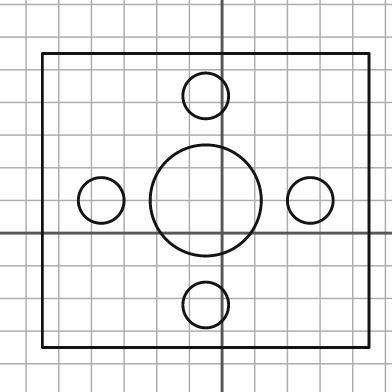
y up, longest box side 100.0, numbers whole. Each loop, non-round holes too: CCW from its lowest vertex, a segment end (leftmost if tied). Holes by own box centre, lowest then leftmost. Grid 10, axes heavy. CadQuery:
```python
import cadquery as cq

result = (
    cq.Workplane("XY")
    .moveTo(-55.0, -35.0)
    .lineTo(45.0, -35.0)
    .lineTo(45.0, 55.0)
    .lineTo(-55.0, 55.0)
    .close()
    .moveTo(-5.0, -22.0)
    .circle(7.0)
    .moveTo(-37.0, 10.0)
    .circle(7.0)
    .moveTo(-5.0, 10.0)
    .circle(17.0)
    .moveTo(27.0, 10.0)
    .circle(7.0)
    .moveTo(-5.0, 42.0)
    .circle(7.0)
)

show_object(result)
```